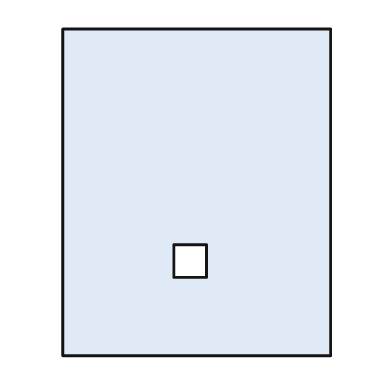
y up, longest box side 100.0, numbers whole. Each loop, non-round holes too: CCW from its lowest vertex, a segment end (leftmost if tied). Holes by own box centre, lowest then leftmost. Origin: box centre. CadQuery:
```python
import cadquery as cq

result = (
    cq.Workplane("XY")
    .moveTo(-41.0, -50.0)
    .lineTo(41.0, -50.0)
    .lineTo(41.0, 50.0)
    .lineTo(-41.0, 50.0)
    .close()
    .moveTo(-7.0, -26.0)
    .lineTo(3.0, -26.0)
    .lineTo(3.0, -16.0)
    .lineTo(-7.0, -16.0)
    .close()
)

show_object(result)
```